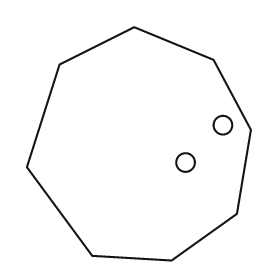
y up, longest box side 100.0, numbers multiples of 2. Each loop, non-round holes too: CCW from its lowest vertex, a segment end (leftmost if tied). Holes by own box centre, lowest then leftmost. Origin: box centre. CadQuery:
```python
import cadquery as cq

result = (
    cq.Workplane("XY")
    .moveTo(14.0, -50.0)
    .lineTo(42.0, -30.0)
    .lineTo(48.0, 6.0)
    .lineTo(32.0, 36.0)
    .lineTo(-2.0, 50.0)
    .lineTo(-34.0, 34.0)
    .lineTo(-48.0, -10.0)
    .lineTo(-20.0, -48.0)
    .close()
    .moveTo(20.0, -8.0)
    .circle(4.0)
    .moveTo(36.0, 8.0)
    .circle(4.0)
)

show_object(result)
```